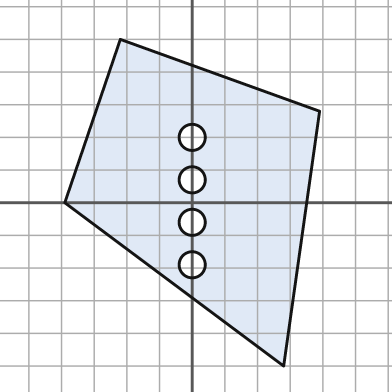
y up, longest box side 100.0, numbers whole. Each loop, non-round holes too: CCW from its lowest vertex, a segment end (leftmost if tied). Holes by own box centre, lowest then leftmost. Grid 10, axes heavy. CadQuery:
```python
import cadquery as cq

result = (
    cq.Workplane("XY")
    .moveTo(28.0, -50.0)
    .lineTo(39.0, 28.0)
    .lineTo(-22.0, 50.0)
    .lineTo(-39.0, 0.0)
    .close()
    .moveTo(0.0, -19.0)
    .circle(4.0)
    .moveTo(0.0, -6.0)
    .circle(4.0)
    .moveTo(0.0, 7.0)
    .circle(4.0)
    .moveTo(0.0, 20.0)
    .circle(4.0)
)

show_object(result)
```